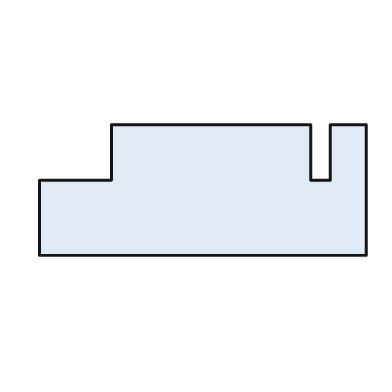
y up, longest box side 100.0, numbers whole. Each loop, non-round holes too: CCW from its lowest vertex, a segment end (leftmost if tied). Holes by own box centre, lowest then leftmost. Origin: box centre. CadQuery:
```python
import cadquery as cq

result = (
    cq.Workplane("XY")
    .moveTo(-50.0, -20.0)
    .lineTo(50.0, -20.0)
    .lineTo(50.0, 20.0)
    .lineTo(39.0, 20.0)
    .lineTo(39.0, 3.0)
    .lineTo(33.0, 3.0)
    .lineTo(33.0, 20.0)
    .lineTo(-28.0, 20.0)
    .lineTo(-28.0, 3.0)
    .lineTo(-50.0, 3.0)
    .close()
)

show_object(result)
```